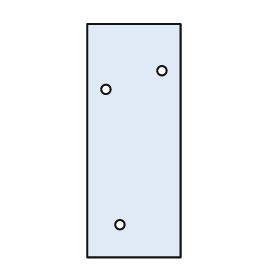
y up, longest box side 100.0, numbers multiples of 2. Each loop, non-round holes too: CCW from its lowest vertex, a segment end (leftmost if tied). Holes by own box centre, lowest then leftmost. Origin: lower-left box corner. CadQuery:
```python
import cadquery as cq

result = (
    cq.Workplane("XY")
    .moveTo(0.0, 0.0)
    .lineTo(40.0, 0.0)
    .lineTo(40.0, 100.0)
    .lineTo(0.0, 100.0)
    .close()
    .moveTo(14.0, 14.0)
    .circle(2.0)
    .moveTo(8.0, 72.0)
    .circle(2.0)
    .moveTo(32.0, 80.0)
    .circle(2.0)
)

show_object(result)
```